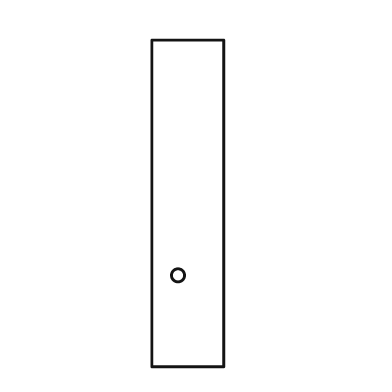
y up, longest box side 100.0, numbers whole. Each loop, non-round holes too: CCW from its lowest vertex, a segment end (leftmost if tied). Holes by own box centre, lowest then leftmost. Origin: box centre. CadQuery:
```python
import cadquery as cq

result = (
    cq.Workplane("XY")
    .moveTo(-11.0, -50.0)
    .lineTo(11.0, -50.0)
    .lineTo(11.0, 50.0)
    .lineTo(-11.0, 50.0)
    .close()
    .moveTo(-3.0, -22.0)
    .circle(2.0)
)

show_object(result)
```